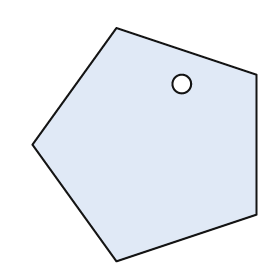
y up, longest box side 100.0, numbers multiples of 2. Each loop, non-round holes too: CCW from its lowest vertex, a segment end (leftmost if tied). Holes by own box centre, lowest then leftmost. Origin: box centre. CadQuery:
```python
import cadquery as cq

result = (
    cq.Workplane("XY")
    .moveTo(-12.0, -50.0)
    .lineTo(48.0, -30.0)
    .lineTo(48.0, 30.0)
    .lineTo(-12.0, 50.0)
    .lineTo(-48.0, 0.0)
    .close()
    .moveTo(16.0, 26.0)
    .circle(4.0)
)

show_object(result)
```